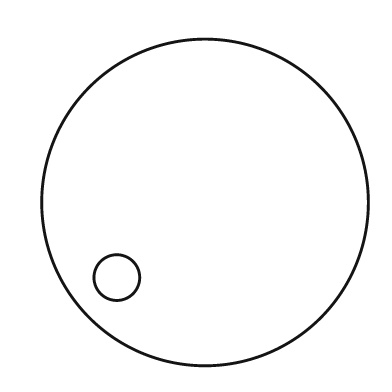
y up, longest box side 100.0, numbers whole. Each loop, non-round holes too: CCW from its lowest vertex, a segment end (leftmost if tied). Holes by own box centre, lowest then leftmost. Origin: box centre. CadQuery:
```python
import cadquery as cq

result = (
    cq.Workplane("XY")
    .moveTo(0.0, 0.0)
    .circle(50.0)
    .moveTo(-27.0, -23.0)
    .circle(7.0)
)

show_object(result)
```